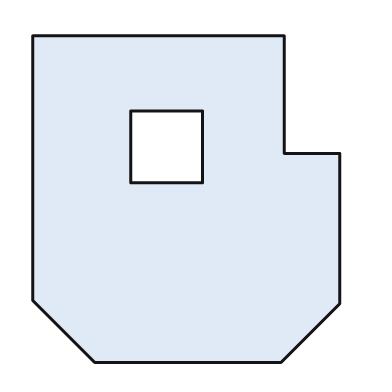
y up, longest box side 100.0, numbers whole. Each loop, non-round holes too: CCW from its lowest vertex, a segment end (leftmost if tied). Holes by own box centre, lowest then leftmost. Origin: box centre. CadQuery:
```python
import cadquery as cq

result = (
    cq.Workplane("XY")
    .moveTo(-28.0, -50.0)
    .lineTo(29.0, -50.0)
    .lineTo(47.0, -32.0)
    .lineTo(47.0, 14.0)
    .lineTo(30.0, 14.0)
    .lineTo(30.0, 50.0)
    .lineTo(-47.0, 50.0)
    .lineTo(-47.0, -31.0)
    .close()
    .moveTo(-17.0, 5.0)
    .lineTo(5.0, 5.0)
    .lineTo(5.0, 27.0)
    .lineTo(-17.0, 27.0)
    .close()
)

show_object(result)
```